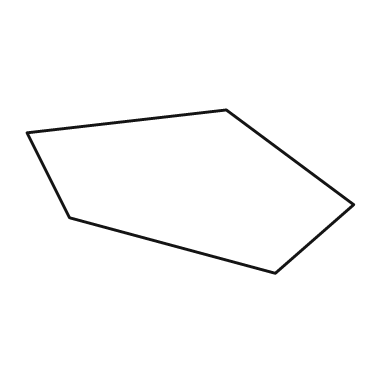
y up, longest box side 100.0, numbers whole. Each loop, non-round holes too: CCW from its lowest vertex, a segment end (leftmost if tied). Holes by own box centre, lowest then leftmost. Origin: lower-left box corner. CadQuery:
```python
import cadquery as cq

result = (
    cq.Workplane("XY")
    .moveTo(76.0, 0.0)
    .lineTo(100.0, 21.0)
    .lineTo(61.0, 50.0)
    .lineTo(0.0, 43.0)
    .lineTo(13.0, 17.0)
    .close()
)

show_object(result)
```